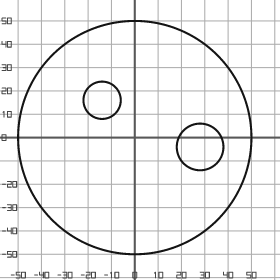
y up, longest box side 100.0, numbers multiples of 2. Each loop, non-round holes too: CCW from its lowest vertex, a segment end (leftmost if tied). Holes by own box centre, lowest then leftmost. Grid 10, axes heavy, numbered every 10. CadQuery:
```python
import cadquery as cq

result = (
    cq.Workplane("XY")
    .moveTo(0.0, 0.0)
    .circle(50.0)
    .moveTo(28.0, -4.0)
    .circle(10.0)
    .moveTo(-14.0, 16.0)
    .circle(8.0)
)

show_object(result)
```